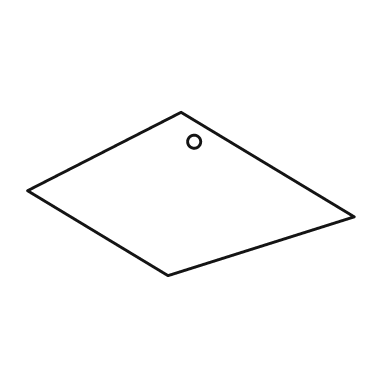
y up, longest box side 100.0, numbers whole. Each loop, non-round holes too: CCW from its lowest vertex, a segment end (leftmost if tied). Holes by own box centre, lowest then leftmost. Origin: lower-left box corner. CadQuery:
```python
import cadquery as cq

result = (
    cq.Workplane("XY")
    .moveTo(43.0, 0.0)
    .lineTo(100.0, 18.0)
    .lineTo(47.0, 50.0)
    .lineTo(0.0, 26.0)
    .close()
    .moveTo(51.0, 41.0)
    .circle(2.0)
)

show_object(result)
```